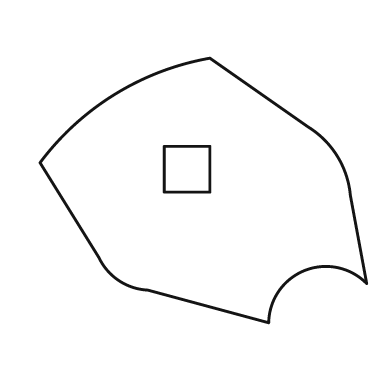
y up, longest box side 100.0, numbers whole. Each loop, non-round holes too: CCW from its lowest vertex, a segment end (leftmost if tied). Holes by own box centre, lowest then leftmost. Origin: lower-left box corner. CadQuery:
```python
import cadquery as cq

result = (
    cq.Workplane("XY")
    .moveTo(70.0, 0.0)
    .threePointArc((81.0, 16.0), (100.0, 12.0))
    .lineTo(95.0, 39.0)
    .threePointArc((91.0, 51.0), (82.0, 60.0))
    .lineTo(52.0, 81.0)
    .threePointArc((23.0, 70.0), (0.0, 49.0))
    .lineTo(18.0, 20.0)
    .threePointArc((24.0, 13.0), (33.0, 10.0))
    .close()
    .moveTo(38.0, 40.0)
    .lineTo(52.0, 40.0)
    .lineTo(52.0, 54.0)
    .lineTo(38.0, 54.0)
    .close()
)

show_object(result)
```